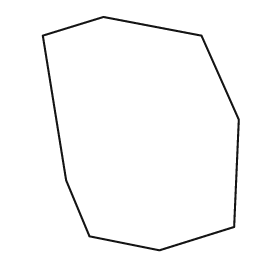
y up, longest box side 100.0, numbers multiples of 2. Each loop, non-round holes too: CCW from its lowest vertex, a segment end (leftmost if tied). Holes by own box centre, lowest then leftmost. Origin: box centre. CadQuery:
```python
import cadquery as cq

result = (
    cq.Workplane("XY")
    .moveTo(8.0, -50.0)
    .lineTo(40.0, -40.0)
    .lineTo(42.0, 6.0)
    .lineTo(26.0, 42.0)
    .lineTo(-16.0, 50.0)
    .lineTo(-42.0, 42.0)
    .lineTo(-32.0, -20.0)
    .lineTo(-22.0, -44.0)
    .close()
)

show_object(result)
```